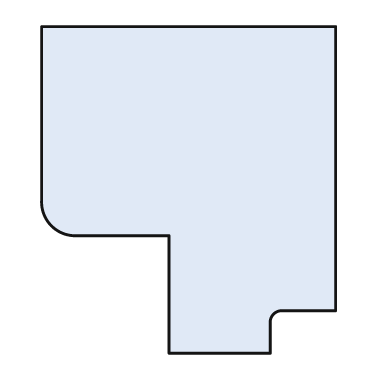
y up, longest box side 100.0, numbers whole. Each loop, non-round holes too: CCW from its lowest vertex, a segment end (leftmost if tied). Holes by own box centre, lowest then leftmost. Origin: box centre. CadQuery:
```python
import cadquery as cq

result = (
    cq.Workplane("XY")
    .moveTo(-6.0, -50.0)
    .lineTo(25.0, -50.0)
    .lineTo(25.0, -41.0)
    .threePointArc((26.0, -38.0), (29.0, -37.0))
    .lineTo(45.0, -37.0)
    .lineTo(45.0, 50.0)
    .lineTo(-45.0, 50.0)
    .lineTo(-45.0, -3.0)
    .threePointArc((-42.0, -11.0), (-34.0, -14.0))
    .lineTo(-6.0, -14.0)
    .close()
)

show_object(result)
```